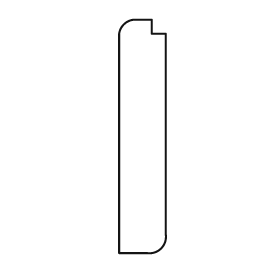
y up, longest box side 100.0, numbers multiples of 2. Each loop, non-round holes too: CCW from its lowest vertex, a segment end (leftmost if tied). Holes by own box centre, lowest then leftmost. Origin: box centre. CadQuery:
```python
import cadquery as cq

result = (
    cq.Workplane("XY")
    .moveTo(-10.0, -50.0)
    .lineTo(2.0, -50.0)
    .threePointArc((8.0, -48.0), (10.0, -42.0))
    .lineTo(10.0, 44.0)
    .lineTo(4.0, 44.0)
    .lineTo(4.0, 50.0)
    .lineTo(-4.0, 50.0)
    .threePointArc((-8.0, 48.0), (-10.0, 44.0))
    .close()
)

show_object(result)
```